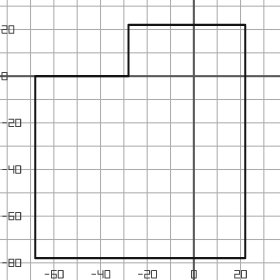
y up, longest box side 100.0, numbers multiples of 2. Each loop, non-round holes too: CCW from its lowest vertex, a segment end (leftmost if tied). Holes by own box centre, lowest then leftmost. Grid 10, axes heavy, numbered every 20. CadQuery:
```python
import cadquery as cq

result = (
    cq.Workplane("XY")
    .moveTo(-68.0, -78.0)
    .lineTo(22.0, -78.0)
    .lineTo(22.0, 22.0)
    .lineTo(-28.0, 22.0)
    .lineTo(-28.0, 0.0)
    .lineTo(-68.0, 0.0)
    .close()
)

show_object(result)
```